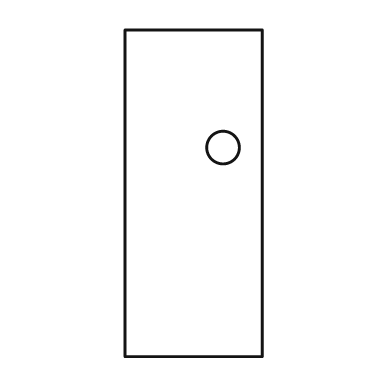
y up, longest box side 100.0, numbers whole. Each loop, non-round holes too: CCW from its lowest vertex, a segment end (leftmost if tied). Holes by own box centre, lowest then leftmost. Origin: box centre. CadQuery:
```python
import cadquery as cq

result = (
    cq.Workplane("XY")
    .moveTo(-21.0, -50.0)
    .lineTo(21.0, -50.0)
    .lineTo(21.0, 50.0)
    .lineTo(-21.0, 50.0)
    .close()
    .moveTo(9.0, 14.0)
    .circle(5.0)
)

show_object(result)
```